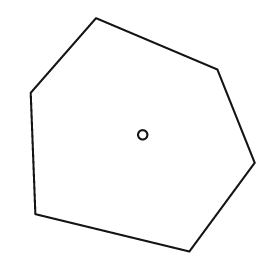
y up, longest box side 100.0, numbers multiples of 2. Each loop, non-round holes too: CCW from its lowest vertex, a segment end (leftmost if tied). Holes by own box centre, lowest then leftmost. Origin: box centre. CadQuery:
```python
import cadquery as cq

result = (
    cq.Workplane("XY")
    .moveTo(20.0, -50.0)
    .lineTo(48.0, -12.0)
    .lineTo(32.0, 28.0)
    .lineTo(-20.0, 50.0)
    .lineTo(-48.0, 18.0)
    .lineTo(-46.0, -34.0)
    .close()
    .moveTo(0.0, 0.0)
    .circle(2.0)
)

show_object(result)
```